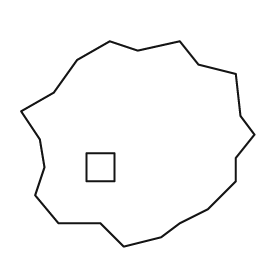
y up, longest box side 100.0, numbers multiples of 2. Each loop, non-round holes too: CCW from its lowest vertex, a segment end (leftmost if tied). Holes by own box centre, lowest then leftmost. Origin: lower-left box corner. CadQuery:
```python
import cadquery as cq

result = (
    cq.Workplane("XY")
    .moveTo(44.0, 0.0)
    .lineTo(60.0, 4.0)
    .lineTo(68.0, 10.0)
    .lineTo(80.0, 16.0)
    .lineTo(92.0, 28.0)
    .lineTo(92.0, 38.0)
    .lineTo(100.0, 48.0)
    .lineTo(94.0, 56.0)
    .lineTo(92.0, 74.0)
    .lineTo(76.0, 78.0)
    .lineTo(68.0, 88.0)
    .lineTo(50.0, 84.0)
    .lineTo(38.0, 88.0)
    .lineTo(24.0, 80.0)
    .lineTo(14.0, 66.0)
    .lineTo(0.0, 58.0)
    .lineTo(8.0, 46.0)
    .lineTo(10.0, 34.0)
    .lineTo(6.0, 22.0)
    .lineTo(16.0, 10.0)
    .lineTo(34.0, 10.0)
    .close()
    .moveTo(28.0, 28.0)
    .lineTo(40.0, 28.0)
    .lineTo(40.0, 40.0)
    .lineTo(28.0, 40.0)
    .close()
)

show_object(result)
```